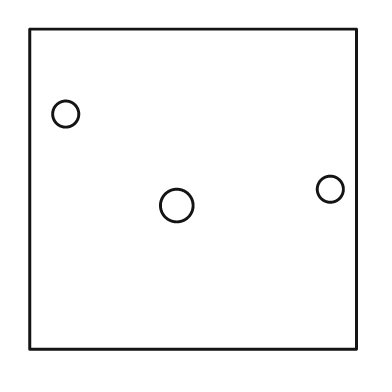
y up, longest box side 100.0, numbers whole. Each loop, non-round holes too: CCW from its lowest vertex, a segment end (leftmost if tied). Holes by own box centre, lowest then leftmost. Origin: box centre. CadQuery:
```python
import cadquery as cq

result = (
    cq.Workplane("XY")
    .moveTo(-50.0, -49.0)
    .lineTo(50.0, -49.0)
    .lineTo(50.0, 49.0)
    .lineTo(-50.0, 49.0)
    .close()
    .moveTo(-5.0, -5.0)
    .circle(5.0)
    .moveTo(42.0, 0.0)
    .circle(4.0)
    .moveTo(-39.0, 23.0)
    .circle(4.0)
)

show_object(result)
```